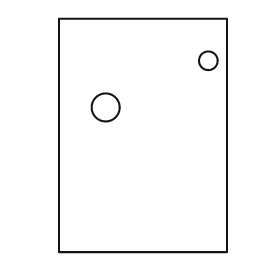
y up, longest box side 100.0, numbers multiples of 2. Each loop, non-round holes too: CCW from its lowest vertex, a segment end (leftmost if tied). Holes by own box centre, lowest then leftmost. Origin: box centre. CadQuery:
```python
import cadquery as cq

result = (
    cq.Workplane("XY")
    .moveTo(-36.0, -50.0)
    .lineTo(36.0, -50.0)
    .lineTo(36.0, 50.0)
    .lineTo(-36.0, 50.0)
    .close()
    .moveTo(-16.0, 12.0)
    .circle(6.0)
    .moveTo(28.0, 32.0)
    .circle(4.0)
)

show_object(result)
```